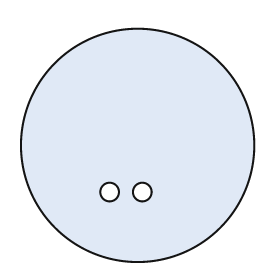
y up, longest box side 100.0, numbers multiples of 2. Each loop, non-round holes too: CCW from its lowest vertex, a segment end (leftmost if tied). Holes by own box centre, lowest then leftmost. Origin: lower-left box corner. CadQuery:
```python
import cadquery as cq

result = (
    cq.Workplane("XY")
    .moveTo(50.0, 50.0)
    .circle(50.0)
    .moveTo(38.0, 30.0)
    .circle(4.0)
    .moveTo(52.0, 30.0)
    .circle(4.0)
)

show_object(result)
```